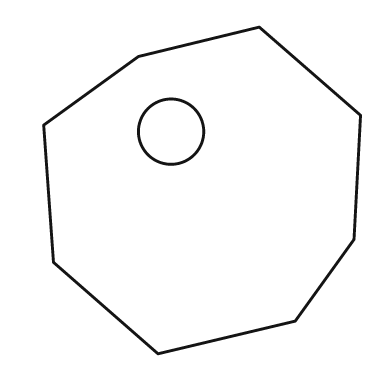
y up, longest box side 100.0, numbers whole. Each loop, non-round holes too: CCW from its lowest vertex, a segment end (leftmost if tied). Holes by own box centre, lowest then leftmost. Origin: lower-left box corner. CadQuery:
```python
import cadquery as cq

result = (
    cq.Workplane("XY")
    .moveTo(35.0, 0.0)
    .lineTo(77.0, 10.0)
    .lineTo(95.0, 35.0)
    .lineTo(97.0, 73.0)
    .lineTo(66.0, 100.0)
    .lineTo(29.0, 91.0)
    .lineTo(0.0, 70.0)
    .lineTo(3.0, 28.0)
    .close()
    .moveTo(39.0, 68.0)
    .circle(10.0)
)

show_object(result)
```